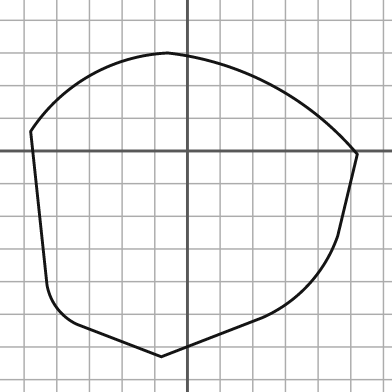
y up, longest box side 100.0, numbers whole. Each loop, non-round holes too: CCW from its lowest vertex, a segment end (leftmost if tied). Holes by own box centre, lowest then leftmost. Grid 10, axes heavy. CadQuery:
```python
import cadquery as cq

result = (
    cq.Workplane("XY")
    .moveTo(-8.0, -63.0)
    .lineTo(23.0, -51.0)
    .threePointArc((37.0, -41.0), (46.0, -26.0))
    .lineTo(52.0, -1.0)
    .threePointArc((26.0, 20.0), (-6.0, 30.0))
    .threePointArc((-30.0, 23.0), (-48.0, 6.0))
    .lineTo(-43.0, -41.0)
    .threePointArc((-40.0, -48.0), (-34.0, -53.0))
    .close()
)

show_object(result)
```